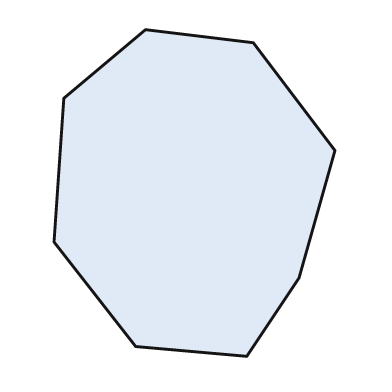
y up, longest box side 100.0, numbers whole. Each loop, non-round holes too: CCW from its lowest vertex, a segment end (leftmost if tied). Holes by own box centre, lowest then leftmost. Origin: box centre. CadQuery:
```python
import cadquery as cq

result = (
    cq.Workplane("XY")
    .moveTo(16.0, -50.0)
    .lineTo(32.0, -26.0)
    .lineTo(43.0, 13.0)
    .lineTo(18.0, 46.0)
    .lineTo(-15.0, 50.0)
    .lineTo(-40.0, 29.0)
    .lineTo(-43.0, -15.0)
    .lineTo(-18.0, -47.0)
    .close()
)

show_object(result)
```